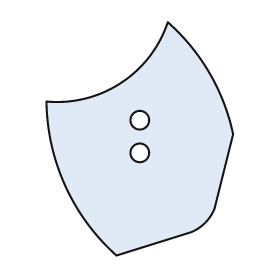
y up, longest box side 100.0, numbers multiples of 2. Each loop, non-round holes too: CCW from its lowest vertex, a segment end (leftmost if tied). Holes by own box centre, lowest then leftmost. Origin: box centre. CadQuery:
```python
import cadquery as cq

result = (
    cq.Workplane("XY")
    .moveTo(-10.0, -50.0)
    .lineTo(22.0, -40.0)
    .threePointArc((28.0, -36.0), (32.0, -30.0))
    .lineTo(40.0, 2.0)
    .threePointArc((30.0, 28.0), (12.0, 50.0))
    .threePointArc((-8.0, 24.0), (-40.0, 16.0))
    .threePointArc((-32.0, -20.0), (-10.0, -50.0))
    .close()
    .moveTo(0.0, -6.0)
    .circle(4.0)
    .moveTo(0.0, 8.0)
    .circle(4.0)
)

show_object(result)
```